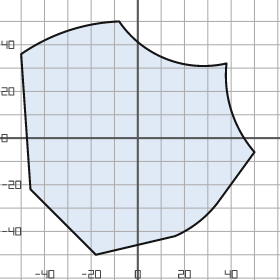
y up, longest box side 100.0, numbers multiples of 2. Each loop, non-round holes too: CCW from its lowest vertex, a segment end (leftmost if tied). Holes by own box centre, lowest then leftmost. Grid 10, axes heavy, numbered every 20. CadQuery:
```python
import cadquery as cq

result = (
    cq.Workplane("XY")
    .moveTo(-18.0, -50.0)
    .lineTo(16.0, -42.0)
    .threePointArc((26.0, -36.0), (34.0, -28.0))
    .lineTo(50.0, -6.0)
    .threePointArc((40.0, 12.0), (38.0, 32.0))
    .threePointArc((12.0, 34.0), (-8.0, 50.0))
    .threePointArc((-30.0, 46.0), (-50.0, 36.0))
    .lineTo(-46.0, -22.0)
    .close()
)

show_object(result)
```